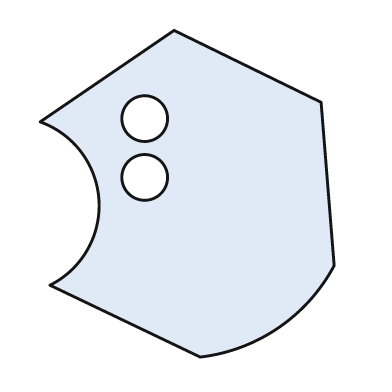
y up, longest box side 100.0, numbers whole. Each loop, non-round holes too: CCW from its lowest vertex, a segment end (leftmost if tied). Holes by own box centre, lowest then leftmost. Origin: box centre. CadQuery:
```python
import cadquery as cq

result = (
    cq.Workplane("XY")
    .moveTo(4.0, -50.0)
    .threePointArc((28.0, -41.0), (45.0, -22.0))
    .lineTo(41.0, 28.0)
    .lineTo(-4.0, 50.0)
    .lineTo(-45.0, 22.0)
    .threePointArc((-27.0, -2.0), (-42.0, -28.0))
    .close()
    .moveTo(-13.0, 5.0)
    .circle(7.0)
    .moveTo(-13.0, 23.0)
    .circle(7.0)
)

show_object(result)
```